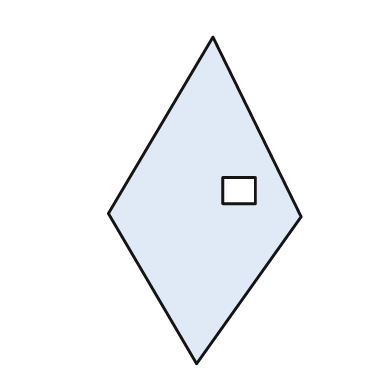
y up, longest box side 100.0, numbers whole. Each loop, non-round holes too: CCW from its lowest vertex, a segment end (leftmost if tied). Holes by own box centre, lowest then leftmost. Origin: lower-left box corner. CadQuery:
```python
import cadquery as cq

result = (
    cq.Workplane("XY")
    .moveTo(27.0, 0.0)
    .lineTo(59.0, 45.0)
    .lineTo(32.0, 100.0)
    .lineTo(0.0, 46.0)
    .close()
    .moveTo(35.0, 49.0)
    .lineTo(45.0, 49.0)
    .lineTo(45.0, 57.0)
    .lineTo(35.0, 57.0)
    .close()
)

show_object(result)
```